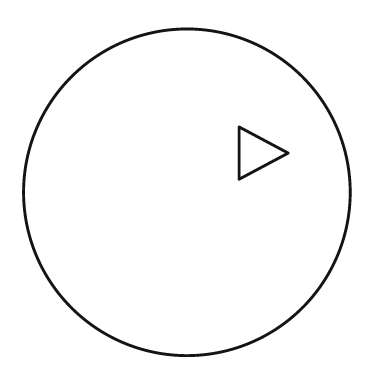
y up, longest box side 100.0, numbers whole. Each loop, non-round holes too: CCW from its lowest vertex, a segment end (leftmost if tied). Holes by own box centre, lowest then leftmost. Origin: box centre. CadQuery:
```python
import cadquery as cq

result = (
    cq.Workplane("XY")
    .moveTo(0.0, 0.0)
    .circle(50.0)
    .moveTo(16.0, 4.0)
    .lineTo(31.0, 12.0)
    .lineTo(16.0, 20.0)
    .close()
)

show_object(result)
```